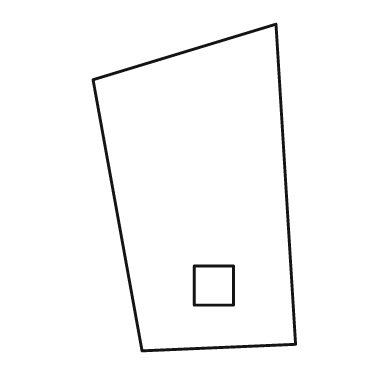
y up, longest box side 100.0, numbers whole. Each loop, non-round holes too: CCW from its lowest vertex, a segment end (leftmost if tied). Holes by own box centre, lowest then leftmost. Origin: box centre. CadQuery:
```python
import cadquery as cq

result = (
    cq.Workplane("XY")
    .moveTo(-16.0, -50.0)
    .lineTo(31.0, -48.0)
    .lineTo(25.0, 50.0)
    .lineTo(-31.0, 33.0)
    .close()
    .moveTo(0.0, -36.0)
    .lineTo(12.0, -36.0)
    .lineTo(12.0, -24.0)
    .lineTo(0.0, -24.0)
    .close()
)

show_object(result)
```